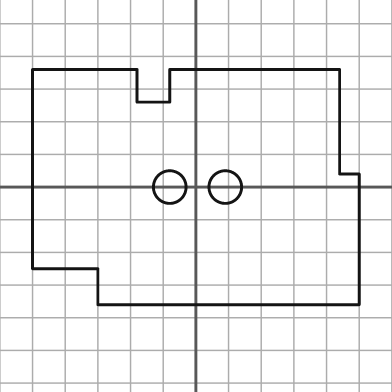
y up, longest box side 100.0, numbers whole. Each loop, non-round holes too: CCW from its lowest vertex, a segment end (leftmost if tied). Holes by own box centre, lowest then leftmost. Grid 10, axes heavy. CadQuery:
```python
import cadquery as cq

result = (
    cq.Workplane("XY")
    .moveTo(-30.0, -36.0)
    .lineTo(50.0, -36.0)
    .lineTo(50.0, 4.0)
    .lineTo(44.0, 4.0)
    .lineTo(44.0, 36.0)
    .lineTo(-8.0, 36.0)
    .lineTo(-8.0, 26.0)
    .lineTo(-18.0, 26.0)
    .lineTo(-18.0, 36.0)
    .lineTo(-50.0, 36.0)
    .lineTo(-50.0, -25.0)
    .lineTo(-30.0, -25.0)
    .close()
    .moveTo(-8.0, 0.0)
    .circle(5.0)
    .moveTo(9.0, 0.0)
    .circle(5.0)
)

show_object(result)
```